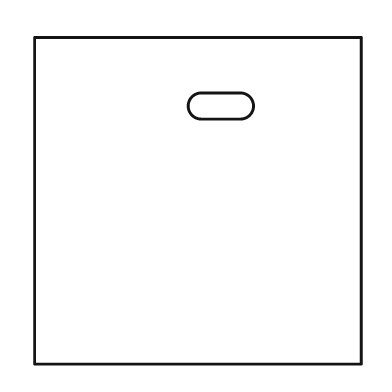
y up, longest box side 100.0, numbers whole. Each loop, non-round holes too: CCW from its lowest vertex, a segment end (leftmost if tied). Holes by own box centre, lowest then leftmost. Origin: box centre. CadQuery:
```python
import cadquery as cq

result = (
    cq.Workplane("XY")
    .moveTo(-50.0, -50.0)
    .lineTo(50.0, -50.0)
    .lineTo(50.0, 50.0)
    .lineTo(-50.0, 50.0)
    .close()
    .moveTo(1.0, 25.0)
    .lineTo(13.0, 25.0)
    .threePointArc((17.0, 29.0), (13.0, 33.0))
    .lineTo(1.0, 33.0)
    .threePointArc((-3.0, 29.0), (1.0, 25.0))
    .close()
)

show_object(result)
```